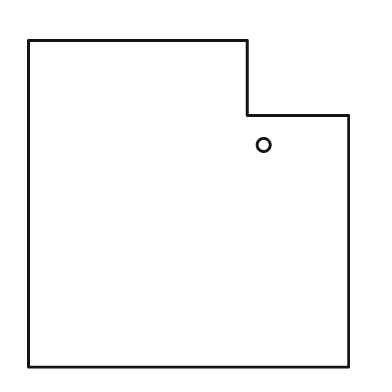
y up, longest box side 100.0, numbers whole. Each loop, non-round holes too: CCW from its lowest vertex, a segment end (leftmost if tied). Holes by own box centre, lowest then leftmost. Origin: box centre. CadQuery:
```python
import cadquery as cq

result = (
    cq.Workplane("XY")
    .moveTo(-49.0, -50.0)
    .lineTo(49.0, -50.0)
    .lineTo(49.0, 27.0)
    .lineTo(18.0, 27.0)
    .lineTo(18.0, 50.0)
    .lineTo(-49.0, 50.0)
    .close()
    .moveTo(23.0, 18.0)
    .circle(2.0)
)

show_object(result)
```